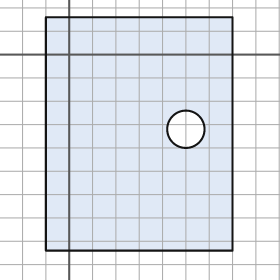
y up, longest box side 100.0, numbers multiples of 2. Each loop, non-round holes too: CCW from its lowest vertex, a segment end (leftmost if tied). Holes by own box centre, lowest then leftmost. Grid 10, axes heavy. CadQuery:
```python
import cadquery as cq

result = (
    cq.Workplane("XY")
    .moveTo(-10.0, -84.0)
    .lineTo(70.0, -84.0)
    .lineTo(70.0, 16.0)
    .lineTo(-10.0, 16.0)
    .close()
    .moveTo(50.0, -32.0)
    .circle(8.0)
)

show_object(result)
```